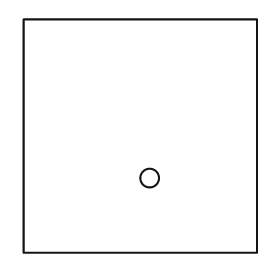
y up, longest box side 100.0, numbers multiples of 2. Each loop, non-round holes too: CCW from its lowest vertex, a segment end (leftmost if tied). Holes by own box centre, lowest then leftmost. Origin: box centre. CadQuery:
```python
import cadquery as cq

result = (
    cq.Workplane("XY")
    .moveTo(-50.0, -50.0)
    .lineTo(50.0, -50.0)
    .lineTo(50.0, 50.0)
    .lineTo(-50.0, 50.0)
    .close()
    .moveTo(4.0, -18.0)
    .circle(4.0)
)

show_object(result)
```